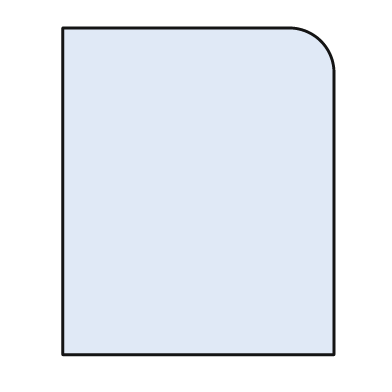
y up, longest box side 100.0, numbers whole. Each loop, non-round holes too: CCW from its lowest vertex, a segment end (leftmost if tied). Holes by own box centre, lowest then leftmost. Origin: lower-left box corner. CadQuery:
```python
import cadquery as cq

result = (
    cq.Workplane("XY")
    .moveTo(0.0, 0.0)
    .lineTo(83.0, 0.0)
    .lineTo(83.0, 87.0)
    .threePointArc((79.0, 96.0), (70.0, 100.0))
    .lineTo(0.0, 100.0)
    .close()
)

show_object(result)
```